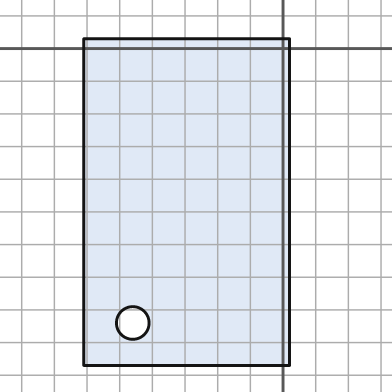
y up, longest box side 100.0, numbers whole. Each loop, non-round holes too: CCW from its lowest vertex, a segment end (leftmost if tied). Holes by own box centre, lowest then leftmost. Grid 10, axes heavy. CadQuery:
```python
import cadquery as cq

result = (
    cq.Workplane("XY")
    .moveTo(-61.0, -97.0)
    .lineTo(2.0, -97.0)
    .lineTo(2.0, 3.0)
    .lineTo(-61.0, 3.0)
    .close()
    .moveTo(-46.0, -84.0)
    .circle(5.0)
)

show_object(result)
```